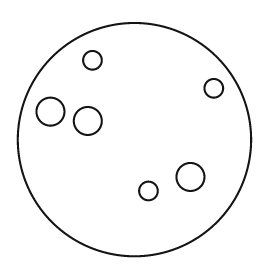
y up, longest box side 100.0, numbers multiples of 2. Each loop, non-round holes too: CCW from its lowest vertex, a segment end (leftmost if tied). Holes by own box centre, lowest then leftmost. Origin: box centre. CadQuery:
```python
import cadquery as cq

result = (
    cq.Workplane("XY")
    .moveTo(0.0, 0.0)
    .circle(50.0)
    .moveTo(6.0, -22.0)
    .circle(4.0)
    .moveTo(24.0, -16.0)
    .circle(6.0)
    .moveTo(-20.0, 8.0)
    .circle(6.0)
    .moveTo(-36.0, 12.0)
    .circle(6.0)
    .moveTo(34.0, 22.0)
    .circle(4.0)
    .moveTo(-18.0, 34.0)
    .circle(4.0)
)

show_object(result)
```